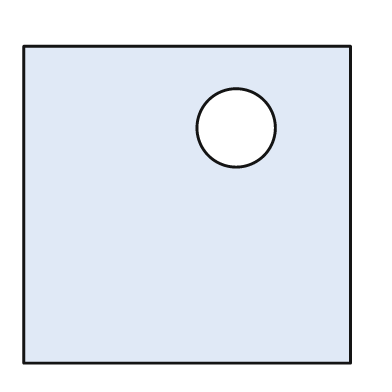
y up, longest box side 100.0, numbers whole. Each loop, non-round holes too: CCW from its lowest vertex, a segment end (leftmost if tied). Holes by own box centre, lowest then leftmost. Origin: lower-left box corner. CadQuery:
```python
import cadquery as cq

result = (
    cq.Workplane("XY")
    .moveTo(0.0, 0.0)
    .lineTo(100.0, 0.0)
    .lineTo(100.0, 97.0)
    .lineTo(0.0, 97.0)
    .close()
    .moveTo(65.0, 72.0)
    .circle(12.0)
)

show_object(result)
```